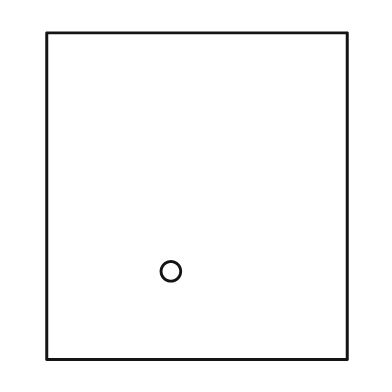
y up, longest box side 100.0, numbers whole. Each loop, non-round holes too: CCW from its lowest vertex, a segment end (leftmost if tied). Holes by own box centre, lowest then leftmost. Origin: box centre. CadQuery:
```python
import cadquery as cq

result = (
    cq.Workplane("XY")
    .moveTo(-46.0, -50.0)
    .lineTo(46.0, -50.0)
    .lineTo(46.0, 50.0)
    .lineTo(-46.0, 50.0)
    .close()
    .moveTo(-8.0, -23.0)
    .circle(3.0)
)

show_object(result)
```